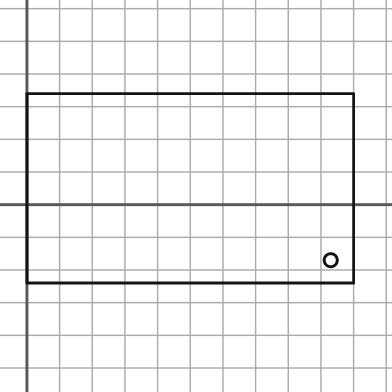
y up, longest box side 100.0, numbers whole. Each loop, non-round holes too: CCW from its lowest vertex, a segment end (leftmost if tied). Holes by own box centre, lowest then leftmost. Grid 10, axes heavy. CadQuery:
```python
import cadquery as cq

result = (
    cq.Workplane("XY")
    .moveTo(0.0, -24.0)
    .lineTo(100.0, -24.0)
    .lineTo(100.0, 34.0)
    .lineTo(0.0, 34.0)
    .close()
    .moveTo(93.0, -17.0)
    .circle(2.0)
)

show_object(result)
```